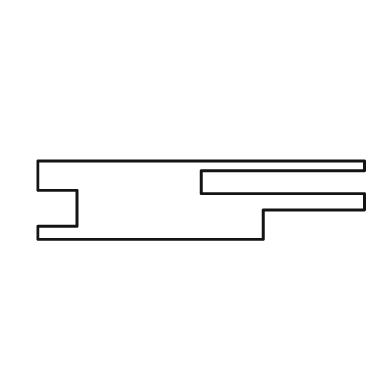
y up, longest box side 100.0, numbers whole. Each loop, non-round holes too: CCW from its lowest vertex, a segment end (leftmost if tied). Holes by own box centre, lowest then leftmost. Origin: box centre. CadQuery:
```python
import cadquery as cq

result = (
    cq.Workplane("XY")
    .moveTo(-50.0, -12.0)
    .lineTo(19.0, -12.0)
    .lineTo(19.0, -3.0)
    .lineTo(50.0, -3.0)
    .lineTo(50.0, 2.0)
    .lineTo(0.0, 2.0)
    .lineTo(0.0, 9.0)
    .lineTo(50.0, 9.0)
    .lineTo(50.0, 12.0)
    .lineTo(-50.0, 12.0)
    .lineTo(-50.0, 3.0)
    .lineTo(-38.0, 3.0)
    .lineTo(-38.0, -8.0)
    .lineTo(-50.0, -8.0)
    .close()
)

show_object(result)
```